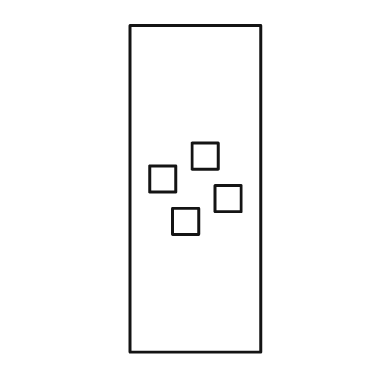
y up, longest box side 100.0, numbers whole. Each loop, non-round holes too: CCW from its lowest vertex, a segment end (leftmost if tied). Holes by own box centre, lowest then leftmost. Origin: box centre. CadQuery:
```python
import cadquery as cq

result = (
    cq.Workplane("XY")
    .moveTo(-20.0, -50.0)
    .lineTo(20.0, -50.0)
    .lineTo(20.0, 50.0)
    .lineTo(-20.0, 50.0)
    .close()
    .moveTo(-7.0, -14.0)
    .lineTo(1.0, -14.0)
    .lineTo(1.0, -6.0)
    .lineTo(-7.0, -6.0)
    .close()
    .moveTo(6.0, -7.0)
    .lineTo(14.0, -7.0)
    .lineTo(14.0, 1.0)
    .lineTo(6.0, 1.0)
    .close()
    .moveTo(-14.0, -1.0)
    .lineTo(-6.0, -1.0)
    .lineTo(-6.0, 7.0)
    .lineTo(-14.0, 7.0)
    .close()
    .moveTo(-1.0, 6.0)
    .lineTo(7.0, 6.0)
    .lineTo(7.0, 14.0)
    .lineTo(-1.0, 14.0)
    .close()
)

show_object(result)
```